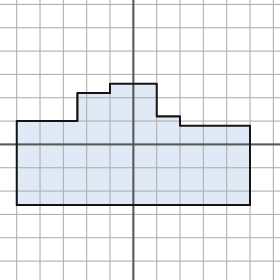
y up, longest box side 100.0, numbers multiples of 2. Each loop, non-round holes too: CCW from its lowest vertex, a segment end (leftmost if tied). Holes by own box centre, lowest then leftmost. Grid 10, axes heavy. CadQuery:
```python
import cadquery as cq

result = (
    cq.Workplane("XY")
    .moveTo(-50.0, -26.0)
    .lineTo(50.0, -26.0)
    .lineTo(50.0, 8.0)
    .lineTo(20.0, 8.0)
    .lineTo(20.0, 12.0)
    .lineTo(10.0, 12.0)
    .lineTo(10.0, 26.0)
    .lineTo(-10.0, 26.0)
    .lineTo(-10.0, 22.0)
    .lineTo(-24.0, 22.0)
    .lineTo(-24.0, 10.0)
    .lineTo(-50.0, 10.0)
    .close()
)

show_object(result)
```